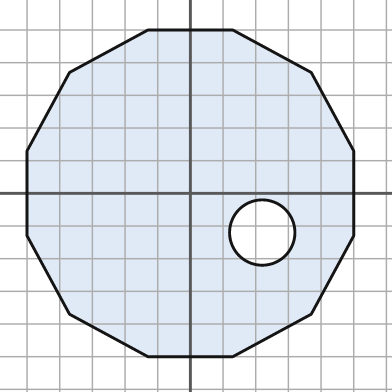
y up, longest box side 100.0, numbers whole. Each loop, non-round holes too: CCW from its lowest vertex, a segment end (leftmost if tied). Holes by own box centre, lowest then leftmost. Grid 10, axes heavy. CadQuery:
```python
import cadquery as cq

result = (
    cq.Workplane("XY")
    .moveTo(-13.0, -50.0)
    .lineTo(13.0, -50.0)
    .lineTo(37.0, -37.0)
    .lineTo(50.0, -13.0)
    .lineTo(50.0, 13.0)
    .lineTo(37.0, 37.0)
    .lineTo(13.0, 50.0)
    .lineTo(-13.0, 50.0)
    .lineTo(-37.0, 37.0)
    .lineTo(-50.0, 13.0)
    .lineTo(-50.0, -13.0)
    .lineTo(-37.0, -37.0)
    .close()
    .moveTo(22.0, -12.0)
    .circle(10.0)
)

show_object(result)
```